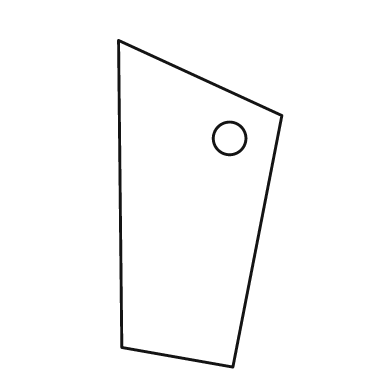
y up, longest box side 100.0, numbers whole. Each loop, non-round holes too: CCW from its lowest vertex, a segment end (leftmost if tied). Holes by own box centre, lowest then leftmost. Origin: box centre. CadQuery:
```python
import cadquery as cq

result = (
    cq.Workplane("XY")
    .moveTo(10.0, -50.0)
    .lineTo(25.0, 27.0)
    .lineTo(-25.0, 50.0)
    .lineTo(-24.0, -44.0)
    .close()
    .moveTo(9.0, 20.0)
    .circle(5.0)
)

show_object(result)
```